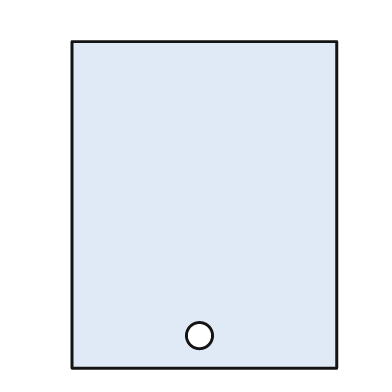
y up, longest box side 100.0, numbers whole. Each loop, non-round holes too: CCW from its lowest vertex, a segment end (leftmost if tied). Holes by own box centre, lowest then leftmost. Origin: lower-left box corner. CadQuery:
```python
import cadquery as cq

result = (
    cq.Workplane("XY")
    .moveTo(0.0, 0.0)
    .lineTo(81.0, 0.0)
    .lineTo(81.0, 100.0)
    .lineTo(0.0, 100.0)
    .close()
    .moveTo(39.0, 10.0)
    .circle(4.0)
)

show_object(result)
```